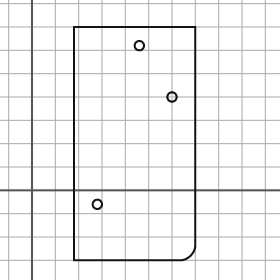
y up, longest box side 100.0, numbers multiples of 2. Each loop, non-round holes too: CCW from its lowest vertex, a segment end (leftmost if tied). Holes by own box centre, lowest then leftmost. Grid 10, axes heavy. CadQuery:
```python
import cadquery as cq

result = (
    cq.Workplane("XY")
    .moveTo(18.0, -30.0)
    .lineTo(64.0, -30.0)
    .threePointArc((68.0, -28.0), (70.0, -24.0))
    .lineTo(70.0, 70.0)
    .lineTo(18.0, 70.0)
    .close()
    .moveTo(28.0, -6.0)
    .circle(2.0)
    .moveTo(60.0, 40.0)
    .circle(2.0)
    .moveTo(46.0, 62.0)
    .circle(2.0)
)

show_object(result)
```